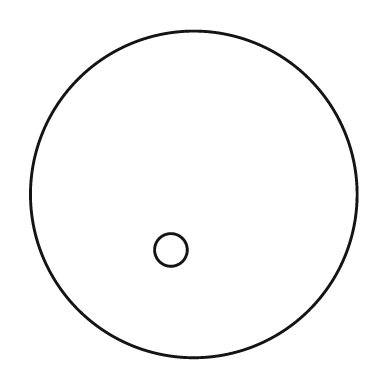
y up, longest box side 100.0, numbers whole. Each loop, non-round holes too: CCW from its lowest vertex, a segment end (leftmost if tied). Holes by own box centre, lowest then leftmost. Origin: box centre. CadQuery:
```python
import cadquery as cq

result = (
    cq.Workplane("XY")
    .moveTo(0.0, 0.0)
    .circle(50.0)
    .moveTo(-7.0, -17.0)
    .circle(5.0)
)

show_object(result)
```